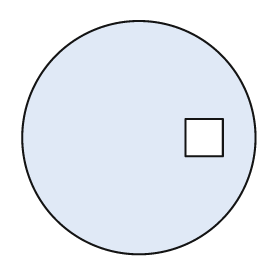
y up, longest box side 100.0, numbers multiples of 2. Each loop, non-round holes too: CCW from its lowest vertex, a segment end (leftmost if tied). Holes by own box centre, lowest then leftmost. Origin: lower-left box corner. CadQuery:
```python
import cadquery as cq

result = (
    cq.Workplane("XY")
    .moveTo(50.0, 50.0)
    .circle(50.0)
    .moveTo(70.0, 42.0)
    .lineTo(86.0, 42.0)
    .lineTo(86.0, 58.0)
    .lineTo(70.0, 58.0)
    .close()
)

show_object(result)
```